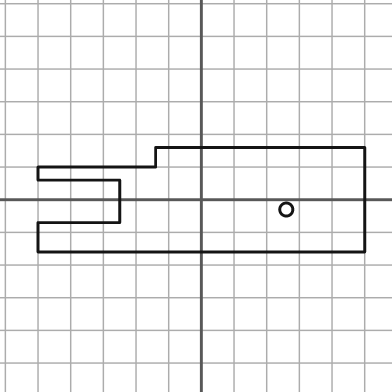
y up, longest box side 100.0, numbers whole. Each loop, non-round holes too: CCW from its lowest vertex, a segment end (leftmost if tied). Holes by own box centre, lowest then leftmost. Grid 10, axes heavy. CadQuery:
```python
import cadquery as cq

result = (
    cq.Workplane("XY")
    .moveTo(-50.0, -16.0)
    .lineTo(50.0, -16.0)
    .lineTo(50.0, 16.0)
    .lineTo(-14.0, 16.0)
    .lineTo(-14.0, 10.0)
    .lineTo(-50.0, 10.0)
    .lineTo(-50.0, 6.0)
    .lineTo(-25.0, 6.0)
    .lineTo(-25.0, -7.0)
    .lineTo(-50.0, -7.0)
    .close()
    .moveTo(26.0, -3.0)
    .circle(2.0)
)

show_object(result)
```